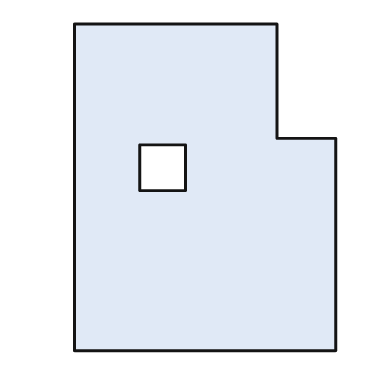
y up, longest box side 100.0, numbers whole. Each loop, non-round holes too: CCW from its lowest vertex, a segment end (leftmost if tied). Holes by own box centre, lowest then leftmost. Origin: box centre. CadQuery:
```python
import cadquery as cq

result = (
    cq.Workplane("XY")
    .moveTo(-40.0, -50.0)
    .lineTo(40.0, -50.0)
    .lineTo(40.0, 15.0)
    .lineTo(22.0, 15.0)
    .lineTo(22.0, 50.0)
    .lineTo(-40.0, 50.0)
    .close()
    .moveTo(-20.0, -1.0)
    .lineTo(-6.0, -1.0)
    .lineTo(-6.0, 13.0)
    .lineTo(-20.0, 13.0)
    .close()
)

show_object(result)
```